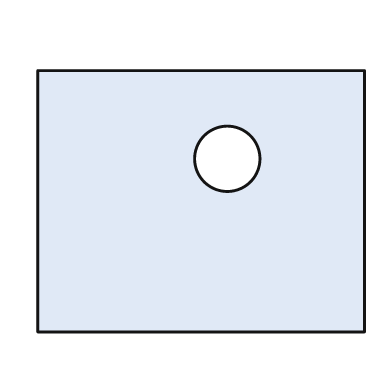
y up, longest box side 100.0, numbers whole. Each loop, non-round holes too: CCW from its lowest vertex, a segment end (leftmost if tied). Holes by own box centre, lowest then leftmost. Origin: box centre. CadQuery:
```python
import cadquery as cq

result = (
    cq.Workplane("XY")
    .moveTo(-50.0, -40.0)
    .lineTo(50.0, -40.0)
    .lineTo(50.0, 40.0)
    .lineTo(-50.0, 40.0)
    .close()
    .moveTo(8.0, 13.0)
    .circle(10.0)
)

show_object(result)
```